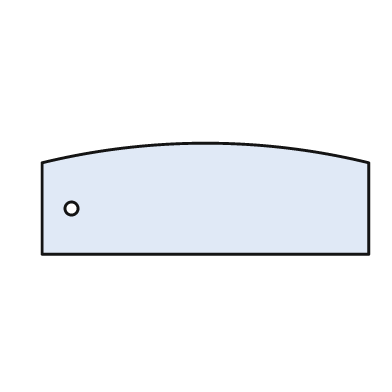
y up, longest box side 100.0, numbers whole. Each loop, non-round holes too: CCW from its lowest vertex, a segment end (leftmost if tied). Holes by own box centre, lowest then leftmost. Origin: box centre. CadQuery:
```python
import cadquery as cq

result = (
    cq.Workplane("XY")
    .moveTo(-50.0, -17.0)
    .lineTo(50.0, -17.0)
    .lineTo(50.0, 11.0)
    .threePointArc((0.0, 17.0), (-50.0, 11.0))
    .close()
    .moveTo(-41.0, -3.0)
    .circle(2.0)
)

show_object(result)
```